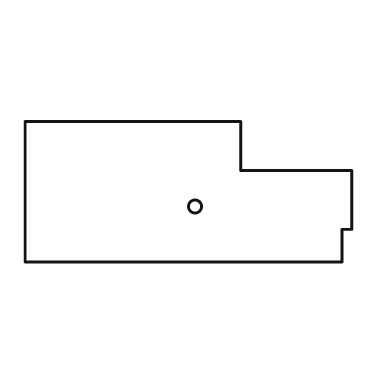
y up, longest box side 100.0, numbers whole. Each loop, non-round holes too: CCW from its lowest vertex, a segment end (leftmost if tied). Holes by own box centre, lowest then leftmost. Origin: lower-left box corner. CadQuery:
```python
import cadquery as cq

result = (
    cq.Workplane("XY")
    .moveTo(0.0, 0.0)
    .lineTo(97.0, 0.0)
    .lineTo(97.0, 10.0)
    .lineTo(100.0, 10.0)
    .lineTo(100.0, 28.0)
    .lineTo(66.0, 28.0)
    .lineTo(66.0, 43.0)
    .lineTo(0.0, 43.0)
    .close()
    .moveTo(52.0, 17.0)
    .circle(2.0)
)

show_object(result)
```